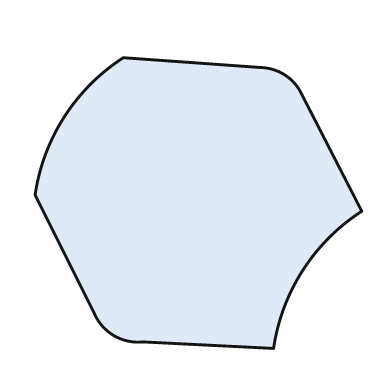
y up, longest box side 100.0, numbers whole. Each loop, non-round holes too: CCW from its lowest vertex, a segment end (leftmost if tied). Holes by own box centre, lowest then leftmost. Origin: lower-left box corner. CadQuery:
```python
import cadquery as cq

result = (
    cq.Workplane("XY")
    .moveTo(73.0, 0.0)
    .threePointArc((82.0, 24.0), (100.0, 42.0))
    .lineTo(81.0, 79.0)
    .threePointArc((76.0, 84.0), (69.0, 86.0))
    .lineTo(27.0, 89.0)
    .threePointArc((9.0, 71.0), (0.0, 47.0))
    .lineTo(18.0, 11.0)
    .threePointArc((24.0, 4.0), (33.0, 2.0))
    .close()
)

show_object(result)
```